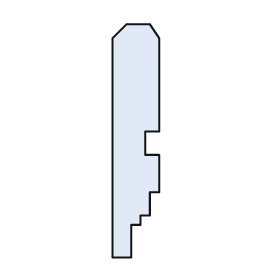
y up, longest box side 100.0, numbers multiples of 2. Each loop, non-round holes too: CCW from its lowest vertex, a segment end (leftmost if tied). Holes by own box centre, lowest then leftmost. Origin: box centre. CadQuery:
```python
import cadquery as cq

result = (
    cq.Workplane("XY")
    .moveTo(-10.0, -50.0)
    .lineTo(-2.0, -50.0)
    .lineTo(-2.0, -36.0)
    .lineTo(2.0, -36.0)
    .lineTo(2.0, -32.0)
    .lineTo(6.0, -32.0)
    .lineTo(6.0, -22.0)
    .lineTo(10.0, -22.0)
    .lineTo(10.0, -6.0)
    .lineTo(4.0, -6.0)
    .lineTo(4.0, 4.0)
    .lineTo(10.0, 4.0)
    .lineTo(10.0, 44.0)
    .lineTo(6.0, 50.0)
    .lineTo(-4.0, 50.0)
    .lineTo(-10.0, 44.0)
    .close()
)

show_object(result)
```